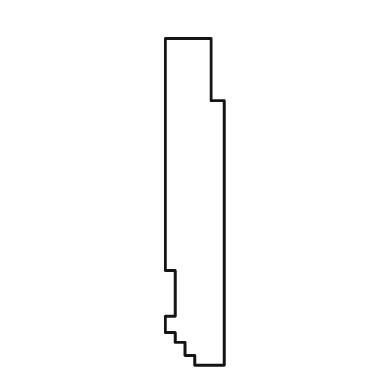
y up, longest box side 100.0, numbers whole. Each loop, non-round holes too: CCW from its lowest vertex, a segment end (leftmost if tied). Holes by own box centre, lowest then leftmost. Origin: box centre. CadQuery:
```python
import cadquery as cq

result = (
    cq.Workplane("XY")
    .moveTo(0.0, -50.0)
    .lineTo(9.0, -50.0)
    .lineTo(9.0, 31.0)
    .lineTo(5.0, 31.0)
    .lineTo(5.0, 50.0)
    .lineTo(-9.0, 50.0)
    .lineTo(-9.0, -21.0)
    .lineTo(-6.0, -21.0)
    .lineTo(-6.0, -35.0)
    .lineTo(-9.0, -35.0)
    .lineTo(-9.0, -40.0)
    .lineTo(-6.0, -40.0)
    .lineTo(-6.0, -43.0)
    .lineTo(-3.0, -43.0)
    .lineTo(-3.0, -47.0)
    .lineTo(0.0, -47.0)
    .close()
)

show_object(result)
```